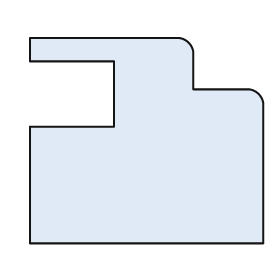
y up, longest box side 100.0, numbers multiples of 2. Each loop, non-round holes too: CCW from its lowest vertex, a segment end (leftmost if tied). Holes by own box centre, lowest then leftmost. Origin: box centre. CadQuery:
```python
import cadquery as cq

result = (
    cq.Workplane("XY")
    .moveTo(-50.0, -44.0)
    .lineTo(50.0, -44.0)
    .lineTo(50.0, 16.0)
    .threePointArc((48.0, 20.0), (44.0, 22.0))
    .lineTo(20.0, 22.0)
    .lineTo(20.0, 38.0)
    .threePointArc((18.0, 42.0), (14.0, 44.0))
    .lineTo(-50.0, 44.0)
    .lineTo(-50.0, 34.0)
    .lineTo(-14.0, 34.0)
    .lineTo(-14.0, 6.0)
    .lineTo(-50.0, 6.0)
    .close()
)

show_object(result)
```